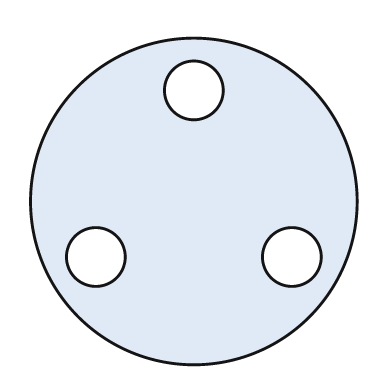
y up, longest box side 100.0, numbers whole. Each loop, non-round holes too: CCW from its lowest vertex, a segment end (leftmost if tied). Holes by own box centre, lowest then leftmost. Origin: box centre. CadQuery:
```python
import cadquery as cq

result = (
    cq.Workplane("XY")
    .moveTo(0.0, 0.0)
    .circle(50.0)
    .moveTo(-30.0, -17.0)
    .circle(9.0)
    .moveTo(30.0, -17.0)
    .circle(9.0)
    .moveTo(0.0, 34.0)
    .circle(9.0)
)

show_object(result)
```